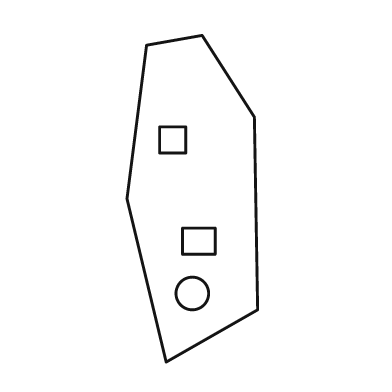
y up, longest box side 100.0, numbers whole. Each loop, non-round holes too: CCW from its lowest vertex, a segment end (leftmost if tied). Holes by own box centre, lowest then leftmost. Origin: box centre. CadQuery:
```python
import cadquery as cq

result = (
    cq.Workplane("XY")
    .moveTo(-8.0, -50.0)
    .lineTo(20.0, -34.0)
    .lineTo(19.0, 25.0)
    .lineTo(3.0, 50.0)
    .lineTo(-14.0, 47.0)
    .lineTo(-20.0, 0.0)
    .close()
    .moveTo(0.0, -29.0)
    .circle(5.0)
    .moveTo(-3.0, -17.0)
    .lineTo(7.0, -17.0)
    .lineTo(7.0, -9.0)
    .lineTo(-3.0, -9.0)
    .close()
    .moveTo(-10.0, 14.0)
    .lineTo(-2.0, 14.0)
    .lineTo(-2.0, 22.0)
    .lineTo(-10.0, 22.0)
    .close()
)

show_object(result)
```